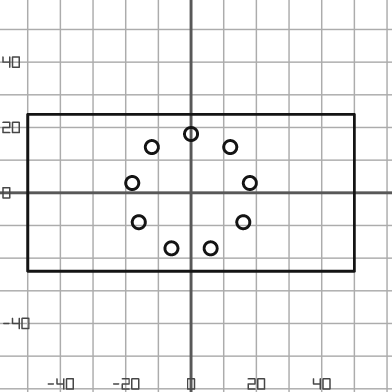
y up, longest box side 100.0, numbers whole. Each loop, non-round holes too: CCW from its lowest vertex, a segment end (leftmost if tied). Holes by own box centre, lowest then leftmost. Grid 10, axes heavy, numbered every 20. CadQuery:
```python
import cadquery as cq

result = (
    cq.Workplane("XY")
    .moveTo(-50.0, -24.0)
    .lineTo(50.0, -24.0)
    .lineTo(50.0, 24.0)
    .lineTo(-50.0, 24.0)
    .close()
    .moveTo(-6.0, -17.0)
    .circle(2.0)
    .moveTo(6.0, -17.0)
    .circle(2.0)
    .moveTo(-16.0, -9.0)
    .circle(2.0)
    .moveTo(16.0, -9.0)
    .circle(2.0)
    .moveTo(-18.0, 3.0)
    .circle(2.0)
    .moveTo(18.0, 3.0)
    .circle(2.0)
    .moveTo(-12.0, 14.0)
    .circle(2.0)
    .moveTo(12.0, 14.0)
    .circle(2.0)
    .moveTo(0.0, 18.0)
    .circle(2.0)
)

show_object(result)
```